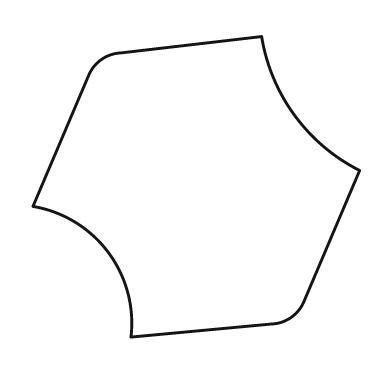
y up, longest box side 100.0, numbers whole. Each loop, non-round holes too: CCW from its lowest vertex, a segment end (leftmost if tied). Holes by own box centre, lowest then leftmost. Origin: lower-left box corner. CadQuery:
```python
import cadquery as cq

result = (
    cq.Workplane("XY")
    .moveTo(30.0, 0.0)
    .lineTo(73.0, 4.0)
    .threePointArc((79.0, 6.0), (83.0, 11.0))
    .lineTo(100.0, 51.0)
    .threePointArc((80.0, 68.0), (70.0, 92.0))
    .lineTo(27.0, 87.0)
    .threePointArc((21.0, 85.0), (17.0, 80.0))
    .lineTo(0.0, 40.0)
    .threePointArc((23.0, 26.0), (30.0, 0.0))
    .close()
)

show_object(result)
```